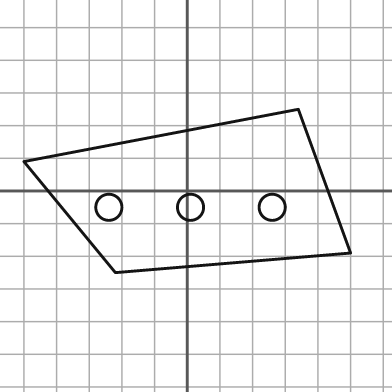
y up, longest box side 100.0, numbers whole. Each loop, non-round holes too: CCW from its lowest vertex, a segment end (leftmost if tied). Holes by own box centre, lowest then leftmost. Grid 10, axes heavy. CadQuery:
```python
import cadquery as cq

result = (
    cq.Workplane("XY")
    .moveTo(-22.0, -25.0)
    .lineTo(50.0, -19.0)
    .lineTo(34.0, 25.0)
    .lineTo(-50.0, 9.0)
    .close()
    .moveTo(-24.0, -5.0)
    .circle(4.0)
    .moveTo(1.0, -5.0)
    .circle(4.0)
    .moveTo(26.0, -5.0)
    .circle(4.0)
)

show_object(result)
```